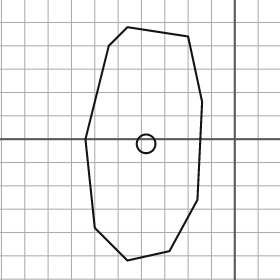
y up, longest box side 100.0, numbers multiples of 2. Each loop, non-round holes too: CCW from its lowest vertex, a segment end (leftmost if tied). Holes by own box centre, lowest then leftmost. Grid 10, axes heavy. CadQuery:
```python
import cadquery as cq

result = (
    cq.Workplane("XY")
    .moveTo(-46.0, -52.0)
    .lineTo(-28.0, -48.0)
    .lineTo(-16.0, -26.0)
    .lineTo(-14.0, 16.0)
    .lineTo(-20.0, 44.0)
    .lineTo(-46.0, 48.0)
    .lineTo(-54.0, 40.0)
    .lineTo(-64.0, 0.0)
    .lineTo(-60.0, -38.0)
    .close()
    .moveTo(-38.0, -2.0)
    .circle(4.0)
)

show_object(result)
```